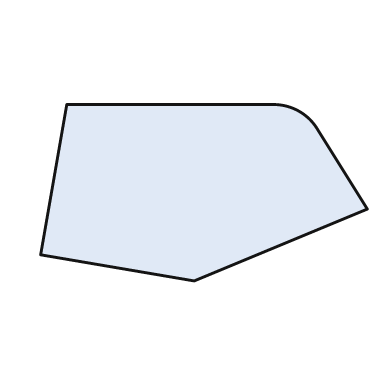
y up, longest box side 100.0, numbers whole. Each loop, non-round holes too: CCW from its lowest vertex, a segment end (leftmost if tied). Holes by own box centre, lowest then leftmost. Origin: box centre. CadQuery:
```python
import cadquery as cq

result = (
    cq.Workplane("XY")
    .moveTo(-3.0, -27.0)
    .lineTo(50.0, -5.0)
    .lineTo(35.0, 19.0)
    .threePointArc((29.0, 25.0), (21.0, 27.0))
    .lineTo(-42.0, 27.0)
    .lineTo(-50.0, -19.0)
    .close()
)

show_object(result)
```